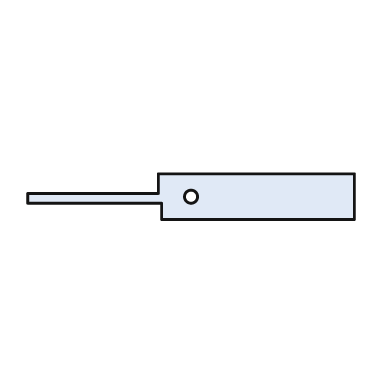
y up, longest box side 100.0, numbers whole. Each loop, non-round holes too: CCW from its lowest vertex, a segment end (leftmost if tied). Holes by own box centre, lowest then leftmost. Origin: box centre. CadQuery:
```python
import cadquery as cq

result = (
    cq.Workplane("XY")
    .moveTo(-9.0, -7.0)
    .lineTo(50.0, -7.0)
    .lineTo(50.0, 7.0)
    .lineTo(-10.0, 7.0)
    .lineTo(-10.0, 1.0)
    .lineTo(-50.0, 1.0)
    .lineTo(-50.0, -2.0)
    .lineTo(-9.0, -2.0)
    .close()
    .moveTo(0.0, 0.0)
    .circle(2.0)
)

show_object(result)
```